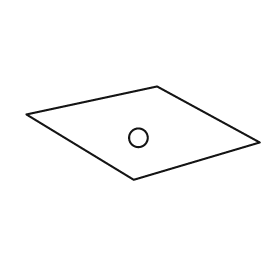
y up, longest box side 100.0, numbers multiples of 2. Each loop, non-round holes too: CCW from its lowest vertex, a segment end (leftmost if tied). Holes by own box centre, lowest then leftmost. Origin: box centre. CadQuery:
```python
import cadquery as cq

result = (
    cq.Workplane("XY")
    .moveTo(-4.0, -20.0)
    .lineTo(50.0, -4.0)
    .lineTo(6.0, 20.0)
    .lineTo(-50.0, 8.0)
    .close()
    .moveTo(-2.0, -2.0)
    .circle(4.0)
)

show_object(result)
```